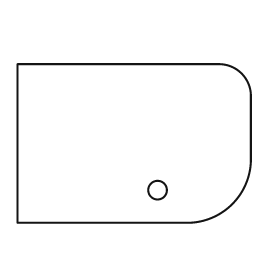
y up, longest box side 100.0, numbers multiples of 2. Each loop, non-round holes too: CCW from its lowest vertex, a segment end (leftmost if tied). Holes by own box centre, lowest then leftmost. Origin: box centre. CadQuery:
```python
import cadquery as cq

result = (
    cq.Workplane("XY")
    .moveTo(-50.0, -34.0)
    .lineTo(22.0, -34.0)
    .threePointArc((42.0, -26.0), (50.0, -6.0))
    .lineTo(50.0, 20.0)
    .threePointArc((46.0, 30.0), (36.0, 34.0))
    .lineTo(-50.0, 34.0)
    .close()
    .moveTo(10.0, -20.0)
    .circle(4.0)
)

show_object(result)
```